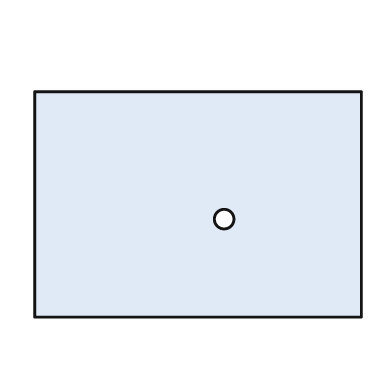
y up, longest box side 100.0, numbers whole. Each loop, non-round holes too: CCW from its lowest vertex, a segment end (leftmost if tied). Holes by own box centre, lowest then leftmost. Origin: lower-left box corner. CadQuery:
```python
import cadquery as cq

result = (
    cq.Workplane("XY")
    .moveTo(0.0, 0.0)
    .lineTo(100.0, 0.0)
    .lineTo(100.0, 69.0)
    .lineTo(0.0, 69.0)
    .close()
    .moveTo(58.0, 30.0)
    .circle(3.0)
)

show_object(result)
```